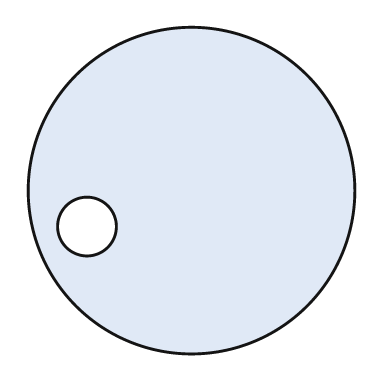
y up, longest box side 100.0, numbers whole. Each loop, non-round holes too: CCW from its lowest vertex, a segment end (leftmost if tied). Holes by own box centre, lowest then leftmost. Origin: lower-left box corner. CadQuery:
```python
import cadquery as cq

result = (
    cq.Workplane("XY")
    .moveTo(50.0, 50.0)
    .circle(50.0)
    .moveTo(18.0, 39.0)
    .circle(9.0)
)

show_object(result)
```